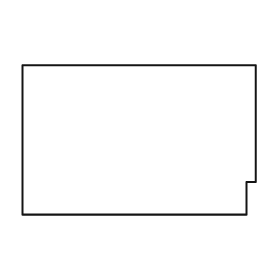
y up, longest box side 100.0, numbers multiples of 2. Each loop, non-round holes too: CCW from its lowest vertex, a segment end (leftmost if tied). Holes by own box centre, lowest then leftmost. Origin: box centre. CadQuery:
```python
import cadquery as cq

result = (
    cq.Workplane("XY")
    .moveTo(-50.0, -32.0)
    .lineTo(46.0, -32.0)
    .lineTo(46.0, -18.0)
    .lineTo(50.0, -18.0)
    .lineTo(50.0, 32.0)
    .lineTo(-50.0, 32.0)
    .close()
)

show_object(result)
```